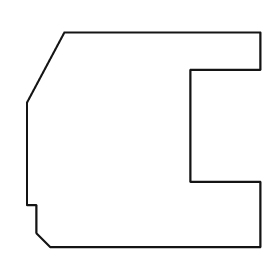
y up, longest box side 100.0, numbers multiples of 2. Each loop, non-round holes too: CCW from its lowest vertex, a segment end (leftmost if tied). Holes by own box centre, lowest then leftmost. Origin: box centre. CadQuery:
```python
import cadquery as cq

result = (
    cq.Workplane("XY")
    .moveTo(-40.0, -46.0)
    .lineTo(50.0, -46.0)
    .lineTo(50.0, -18.0)
    .lineTo(20.0, -18.0)
    .lineTo(20.0, 30.0)
    .lineTo(50.0, 30.0)
    .lineTo(50.0, 46.0)
    .lineTo(-34.0, 46.0)
    .lineTo(-50.0, 16.0)
    .lineTo(-50.0, -28.0)
    .lineTo(-46.0, -28.0)
    .lineTo(-46.0, -40.0)
    .close()
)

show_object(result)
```